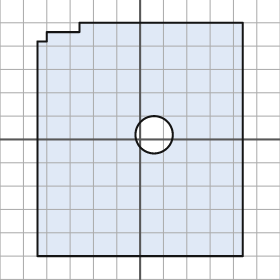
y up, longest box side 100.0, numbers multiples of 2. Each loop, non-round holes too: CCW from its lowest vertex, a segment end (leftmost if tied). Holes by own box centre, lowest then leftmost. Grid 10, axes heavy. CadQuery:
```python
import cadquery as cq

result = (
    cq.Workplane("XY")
    .moveTo(-44.0, -50.0)
    .lineTo(44.0, -50.0)
    .lineTo(44.0, 50.0)
    .lineTo(-26.0, 50.0)
    .lineTo(-26.0, 46.0)
    .lineTo(-40.0, 46.0)
    .lineTo(-40.0, 42.0)
    .lineTo(-44.0, 42.0)
    .close()
    .moveTo(6.0, 2.0)
    .circle(8.0)
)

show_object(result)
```